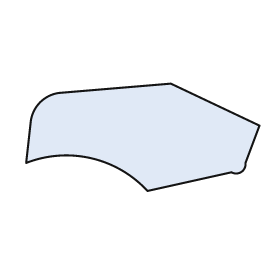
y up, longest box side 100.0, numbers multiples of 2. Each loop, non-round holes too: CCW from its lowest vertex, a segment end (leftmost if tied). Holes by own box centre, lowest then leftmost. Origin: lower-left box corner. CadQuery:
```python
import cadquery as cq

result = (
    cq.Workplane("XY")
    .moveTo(52.0, 0.0)
    .lineTo(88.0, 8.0)
    .threePointArc((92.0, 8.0), (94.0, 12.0))
    .lineTo(100.0, 28.0)
    .lineTo(62.0, 46.0)
    .lineTo(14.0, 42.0)
    .threePointArc((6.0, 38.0), (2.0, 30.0))
    .lineTo(0.0, 12.0)
    .threePointArc((28.0, 14.0), (52.0, 0.0))
    .close()
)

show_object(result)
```